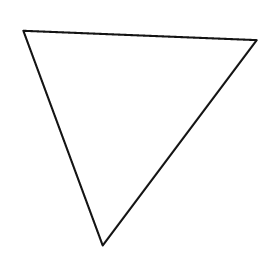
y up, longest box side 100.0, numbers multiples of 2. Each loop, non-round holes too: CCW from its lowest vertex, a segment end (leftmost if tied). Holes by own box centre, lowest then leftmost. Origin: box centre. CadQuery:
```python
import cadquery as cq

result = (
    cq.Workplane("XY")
    .moveTo(-16.0, -46.0)
    .lineTo(50.0, 42.0)
    .lineTo(-50.0, 46.0)
    .close()
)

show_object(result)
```